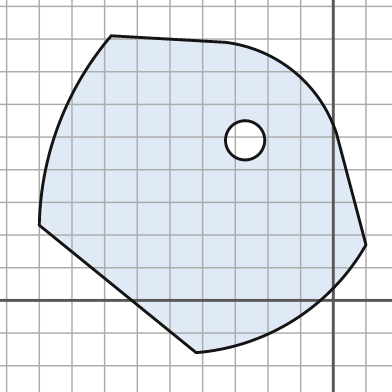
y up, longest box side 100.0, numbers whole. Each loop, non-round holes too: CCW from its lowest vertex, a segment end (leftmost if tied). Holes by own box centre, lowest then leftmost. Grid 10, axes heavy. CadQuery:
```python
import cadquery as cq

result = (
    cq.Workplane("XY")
    .moveTo(-42.0, -16.0)
    .threePointArc((-12.0, -6.0), (10.0, 17.0))
    .lineTo(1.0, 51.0)
    .threePointArc((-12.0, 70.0), (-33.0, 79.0))
    .lineTo(-68.0, 81.0)
    .threePointArc((-84.0, 54.0), (-90.0, 23.0))
    .close()
    .moveTo(-27.0, 49.0)
    .circle(6.0)
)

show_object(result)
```